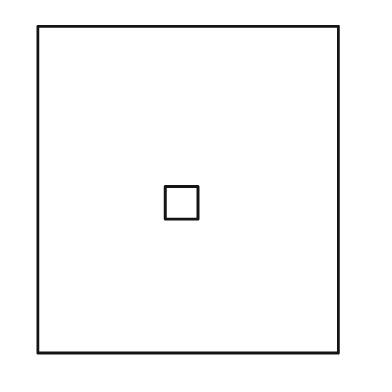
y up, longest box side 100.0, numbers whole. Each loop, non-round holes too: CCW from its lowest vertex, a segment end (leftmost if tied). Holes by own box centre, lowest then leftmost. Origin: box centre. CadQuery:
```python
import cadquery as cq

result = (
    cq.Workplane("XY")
    .moveTo(-46.0, -50.0)
    .lineTo(46.0, -50.0)
    .lineTo(46.0, 50.0)
    .lineTo(-46.0, 50.0)
    .close()
    .moveTo(-7.0, -9.0)
    .lineTo(3.0, -9.0)
    .lineTo(3.0, 1.0)
    .lineTo(-7.0, 1.0)
    .close()
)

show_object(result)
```